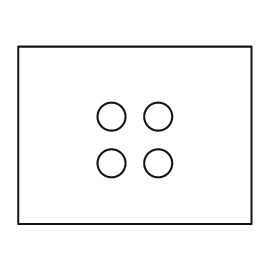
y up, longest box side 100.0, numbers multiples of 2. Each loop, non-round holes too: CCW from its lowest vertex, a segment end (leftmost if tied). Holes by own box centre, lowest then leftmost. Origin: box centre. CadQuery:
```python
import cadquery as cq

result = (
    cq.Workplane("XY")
    .moveTo(-50.0, -38.0)
    .lineTo(50.0, -38.0)
    .lineTo(50.0, 38.0)
    .lineTo(-50.0, 38.0)
    .close()
    .moveTo(-10.0, -12.0)
    .circle(6.0)
    .moveTo(10.0, -12.0)
    .circle(6.0)
    .moveTo(-10.0, 8.0)
    .circle(6.0)
    .moveTo(10.0, 8.0)
    .circle(6.0)
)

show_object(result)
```